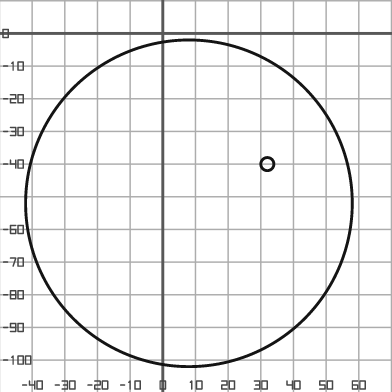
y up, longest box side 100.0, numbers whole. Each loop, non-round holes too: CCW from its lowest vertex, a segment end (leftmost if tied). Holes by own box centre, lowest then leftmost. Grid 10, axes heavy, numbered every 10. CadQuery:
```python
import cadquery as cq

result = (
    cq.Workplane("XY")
    .moveTo(8.0, -52.0)
    .circle(50.0)
    .moveTo(32.0, -40.0)
    .circle(2.0)
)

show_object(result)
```